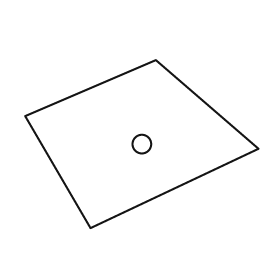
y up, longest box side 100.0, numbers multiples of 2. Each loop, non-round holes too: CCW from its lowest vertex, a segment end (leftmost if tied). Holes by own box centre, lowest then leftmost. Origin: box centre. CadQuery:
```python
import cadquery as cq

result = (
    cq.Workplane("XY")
    .moveTo(-22.0, -36.0)
    .lineTo(50.0, -2.0)
    .lineTo(6.0, 36.0)
    .lineTo(-50.0, 12.0)
    .close()
    .moveTo(0.0, 0.0)
    .circle(4.0)
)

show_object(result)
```